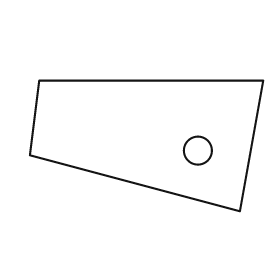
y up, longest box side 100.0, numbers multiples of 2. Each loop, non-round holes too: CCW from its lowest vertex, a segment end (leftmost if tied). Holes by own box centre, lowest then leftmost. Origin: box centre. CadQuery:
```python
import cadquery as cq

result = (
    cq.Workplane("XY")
    .moveTo(40.0, -28.0)
    .lineTo(50.0, 28.0)
    .lineTo(-46.0, 28.0)
    .lineTo(-50.0, -4.0)
    .close()
    .moveTo(22.0, -2.0)
    .circle(6.0)
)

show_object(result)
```